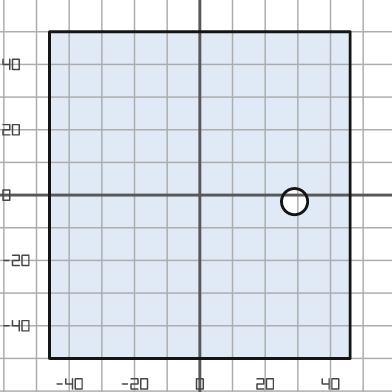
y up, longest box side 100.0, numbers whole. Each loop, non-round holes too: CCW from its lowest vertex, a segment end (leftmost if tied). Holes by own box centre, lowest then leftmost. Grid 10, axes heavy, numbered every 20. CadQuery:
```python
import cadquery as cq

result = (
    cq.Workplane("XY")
    .moveTo(-46.0, -50.0)
    .lineTo(46.0, -50.0)
    .lineTo(46.0, 50.0)
    .lineTo(-46.0, 50.0)
    .close()
    .moveTo(29.0, -2.0)
    .circle(4.0)
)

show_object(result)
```